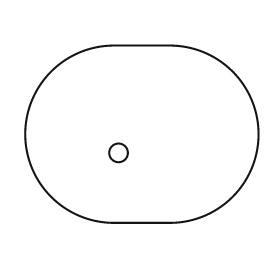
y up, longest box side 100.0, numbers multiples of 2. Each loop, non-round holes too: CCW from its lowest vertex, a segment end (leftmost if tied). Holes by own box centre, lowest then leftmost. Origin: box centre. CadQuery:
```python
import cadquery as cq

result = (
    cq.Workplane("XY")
    .moveTo(-12.0, -38.0)
    .lineTo(12.0, -38.0)
    .threePointArc((50.0, 0.0), (12.0, 38.0))
    .lineTo(-12.0, 38.0)
    .threePointArc((-50.0, 0.0), (-12.0, -38.0))
    .close()
    .moveTo(-10.0, -8.0)
    .circle(4.0)
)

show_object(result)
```